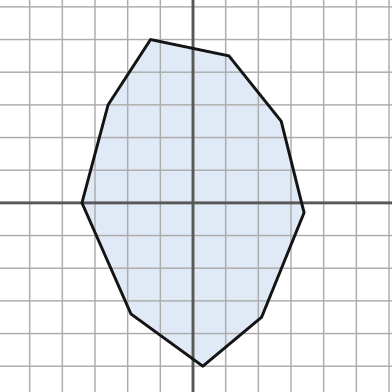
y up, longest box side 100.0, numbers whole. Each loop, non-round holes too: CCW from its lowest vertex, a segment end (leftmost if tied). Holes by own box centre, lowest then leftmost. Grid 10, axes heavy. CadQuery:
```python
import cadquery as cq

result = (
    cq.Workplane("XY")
    .moveTo(3.0, -50.0)
    .lineTo(21.0, -35.0)
    .lineTo(34.0, -3.0)
    .lineTo(27.0, 25.0)
    .lineTo(11.0, 45.0)
    .lineTo(-13.0, 50.0)
    .lineTo(-26.0, 30.0)
    .lineTo(-34.0, 0.0)
    .lineTo(-19.0, -34.0)
    .close()
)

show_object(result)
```